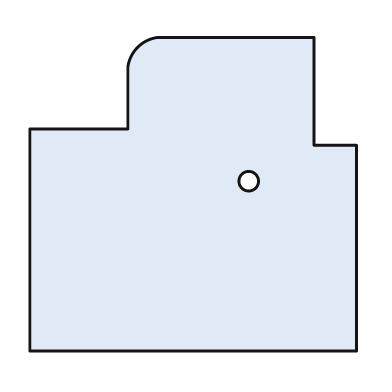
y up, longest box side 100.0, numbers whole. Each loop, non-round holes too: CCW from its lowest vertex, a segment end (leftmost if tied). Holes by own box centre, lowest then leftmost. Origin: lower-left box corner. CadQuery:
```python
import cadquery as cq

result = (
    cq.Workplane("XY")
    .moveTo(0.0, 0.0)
    .lineTo(100.0, 0.0)
    .lineTo(100.0, 63.0)
    .lineTo(87.0, 63.0)
    .lineTo(87.0, 96.0)
    .lineTo(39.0, 96.0)
    .threePointArc((33.0, 93.0), (30.0, 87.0))
    .lineTo(30.0, 68.0)
    .lineTo(0.0, 68.0)
    .close()
    .moveTo(67.0, 52.0)
    .circle(3.0)
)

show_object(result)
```